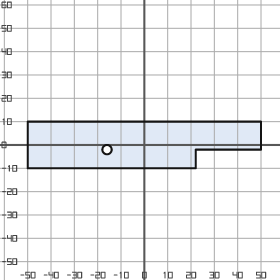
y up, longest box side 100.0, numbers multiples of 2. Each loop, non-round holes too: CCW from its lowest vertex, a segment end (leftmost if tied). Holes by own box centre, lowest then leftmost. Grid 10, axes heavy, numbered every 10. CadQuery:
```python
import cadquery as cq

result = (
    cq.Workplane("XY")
    .moveTo(-50.0, -10.0)
    .lineTo(22.0, -10.0)
    .lineTo(22.0, -2.0)
    .lineTo(50.0, -2.0)
    .lineTo(50.0, 10.0)
    .lineTo(-50.0, 10.0)
    .close()
    .moveTo(-16.0, -2.0)
    .circle(2.0)
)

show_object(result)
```